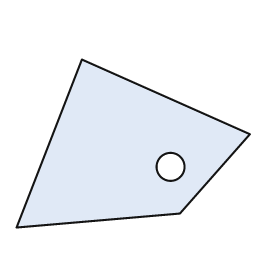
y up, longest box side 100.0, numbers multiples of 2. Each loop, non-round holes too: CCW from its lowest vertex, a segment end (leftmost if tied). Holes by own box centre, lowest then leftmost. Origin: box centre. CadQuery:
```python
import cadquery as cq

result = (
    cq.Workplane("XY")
    .moveTo(-50.0, -36.0)
    .lineTo(20.0, -30.0)
    .lineTo(50.0, 4.0)
    .lineTo(-22.0, 36.0)
    .close()
    .moveTo(16.0, -10.0)
    .circle(6.0)
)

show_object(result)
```